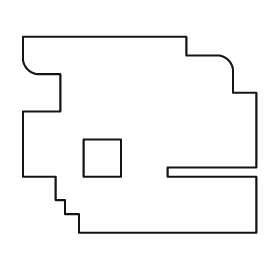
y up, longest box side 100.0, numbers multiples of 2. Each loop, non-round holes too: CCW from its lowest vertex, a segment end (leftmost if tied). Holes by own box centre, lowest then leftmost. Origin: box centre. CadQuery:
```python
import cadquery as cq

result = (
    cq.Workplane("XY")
    .moveTo(-26.0, -42.0)
    .lineTo(50.0, -42.0)
    .lineTo(50.0, -18.0)
    .lineTo(12.0, -18.0)
    .lineTo(12.0, -14.0)
    .lineTo(50.0, -14.0)
    .lineTo(50.0, 18.0)
    .lineTo(40.0, 18.0)
    .lineTo(40.0, 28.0)
    .threePointArc((38.0, 32.0), (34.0, 34.0))
    .lineTo(20.0, 34.0)
    .lineTo(20.0, 42.0)
    .lineTo(-50.0, 42.0)
    .lineTo(-50.0, 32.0)
    .threePointArc((-48.0, 28.0), (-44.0, 26.0))
    .lineTo(-34.0, 26.0)
    .lineTo(-34.0, 10.0)
    .lineTo(-50.0, 10.0)
    .lineTo(-50.0, -18.0)
    .lineTo(-36.0, -18.0)
    .lineTo(-36.0, -28.0)
    .lineTo(-32.0, -28.0)
    .lineTo(-32.0, -34.0)
    .lineTo(-26.0, -34.0)
    .close()
    .moveTo(-24.0, -18.0)
    .lineTo(-8.0, -18.0)
    .lineTo(-8.0, -2.0)
    .lineTo(-24.0, -2.0)
    .close()
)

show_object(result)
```